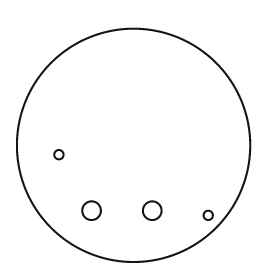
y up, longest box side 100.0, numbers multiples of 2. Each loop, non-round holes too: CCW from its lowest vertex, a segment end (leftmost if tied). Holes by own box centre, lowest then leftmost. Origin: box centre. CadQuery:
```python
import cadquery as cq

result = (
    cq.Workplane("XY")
    .moveTo(0.0, 0.0)
    .circle(50.0)
    .moveTo(32.0, -30.0)
    .circle(2.0)
    .moveTo(-18.0, -28.0)
    .circle(4.0)
    .moveTo(8.0, -28.0)
    .circle(4.0)
    .moveTo(-32.0, -4.0)
    .circle(2.0)
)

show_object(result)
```